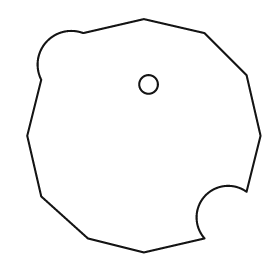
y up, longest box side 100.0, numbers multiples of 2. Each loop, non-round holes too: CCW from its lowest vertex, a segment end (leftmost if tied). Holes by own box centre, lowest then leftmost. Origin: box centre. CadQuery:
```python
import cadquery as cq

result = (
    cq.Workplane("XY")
    .moveTo(0.0, -50.0)
    .lineTo(26.0, -44.0)
    .threePointArc((26.0, -26.0), (44.0, -24.0))
    .lineTo(50.0, 0.0)
    .lineTo(44.0, 26.0)
    .lineTo(26.0, 44.0)
    .lineTo(0.0, 50.0)
    .lineTo(-26.0, 44.0)
    .threePointArc((-42.0, 40.0), (-44.0, 24.0))
    .lineTo(-50.0, 0.0)
    .lineTo(-44.0, -26.0)
    .lineTo(-24.0, -44.0)
    .close()
    .moveTo(2.0, 22.0)
    .circle(4.0)
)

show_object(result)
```